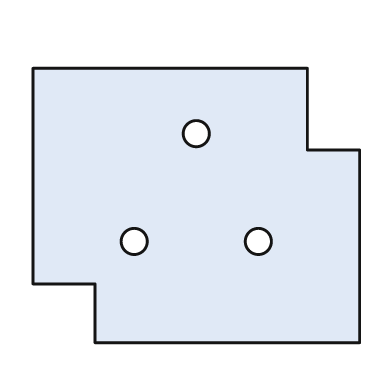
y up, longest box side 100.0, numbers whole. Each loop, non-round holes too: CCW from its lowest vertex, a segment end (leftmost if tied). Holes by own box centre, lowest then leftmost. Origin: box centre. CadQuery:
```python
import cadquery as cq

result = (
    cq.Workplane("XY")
    .moveTo(-31.0, -42.0)
    .lineTo(50.0, -42.0)
    .lineTo(50.0, 17.0)
    .lineTo(34.0, 17.0)
    .lineTo(34.0, 42.0)
    .lineTo(-50.0, 42.0)
    .lineTo(-50.0, -24.0)
    .lineTo(-31.0, -24.0)
    .close()
    .moveTo(-19.0, -11.0)
    .circle(4.0)
    .moveTo(19.0, -11.0)
    .circle(4.0)
    .moveTo(0.0, 22.0)
    .circle(4.0)
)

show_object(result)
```